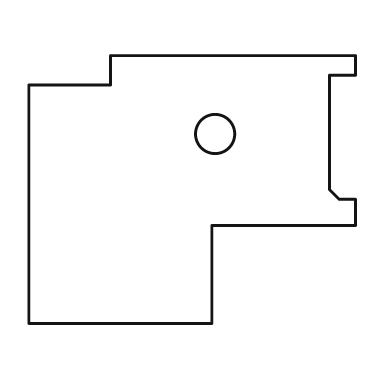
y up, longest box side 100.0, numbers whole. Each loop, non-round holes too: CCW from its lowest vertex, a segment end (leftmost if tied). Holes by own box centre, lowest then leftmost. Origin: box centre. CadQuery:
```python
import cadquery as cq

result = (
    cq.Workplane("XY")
    .moveTo(-50.0, -41.0)
    .lineTo(6.0, -41.0)
    .lineTo(6.0, -11.0)
    .lineTo(50.0, -11.0)
    .lineTo(50.0, -3.0)
    .lineTo(45.0, -3.0)
    .lineTo(42.0, 0.0)
    .lineTo(42.0, 35.0)
    .lineTo(50.0, 35.0)
    .lineTo(50.0, 41.0)
    .lineTo(-25.0, 41.0)
    .lineTo(-25.0, 32.0)
    .lineTo(-50.0, 32.0)
    .close()
    .moveTo(7.0, 17.0)
    .circle(6.0)
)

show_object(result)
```